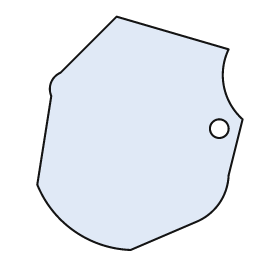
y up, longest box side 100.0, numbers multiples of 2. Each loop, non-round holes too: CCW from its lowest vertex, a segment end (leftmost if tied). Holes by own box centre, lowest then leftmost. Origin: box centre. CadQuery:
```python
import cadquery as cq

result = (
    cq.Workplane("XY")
    .moveTo(-4.0, -50.0)
    .lineTo(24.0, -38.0)
    .threePointArc((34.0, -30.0), (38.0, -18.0))
    .lineTo(44.0, 6.0)
    .threePointArc((36.0, 20.0), (38.0, 36.0))
    .lineTo(-10.0, 50.0)
    .lineTo(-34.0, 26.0)
    .threePointArc((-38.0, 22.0), (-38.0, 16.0))
    .lineTo(-44.0, -22.0)
    .threePointArc((-28.0, -42.0), (-4.0, -50.0))
    .close()
    .moveTo(34.0, 2.0)
    .circle(4.0)
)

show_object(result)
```